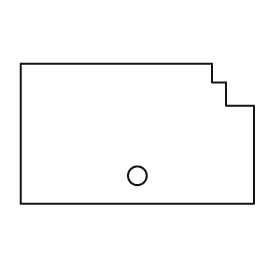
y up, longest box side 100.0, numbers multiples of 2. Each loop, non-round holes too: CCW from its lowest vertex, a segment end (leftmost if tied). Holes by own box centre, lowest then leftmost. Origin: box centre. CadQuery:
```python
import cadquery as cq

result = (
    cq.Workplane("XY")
    .moveTo(-50.0, -30.0)
    .lineTo(50.0, -30.0)
    .lineTo(50.0, 12.0)
    .lineTo(38.0, 12.0)
    .lineTo(38.0, 22.0)
    .lineTo(32.0, 22.0)
    .lineTo(32.0, 30.0)
    .lineTo(-50.0, 30.0)
    .close()
    .moveTo(0.0, -18.0)
    .circle(4.0)
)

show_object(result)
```